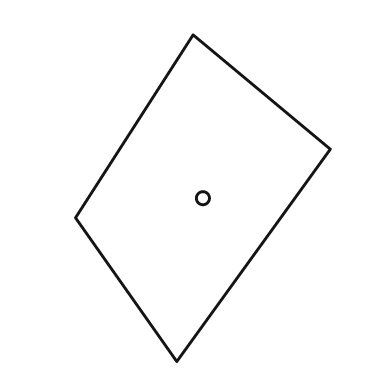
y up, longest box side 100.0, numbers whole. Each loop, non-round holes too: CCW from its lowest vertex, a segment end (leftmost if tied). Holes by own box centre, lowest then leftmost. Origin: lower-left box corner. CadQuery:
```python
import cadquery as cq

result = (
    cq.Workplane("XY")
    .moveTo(31.0, 0.0)
    .lineTo(78.0, 65.0)
    .lineTo(36.0, 100.0)
    .lineTo(0.0, 44.0)
    .close()
    .moveTo(39.0, 50.0)
    .circle(2.0)
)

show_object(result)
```